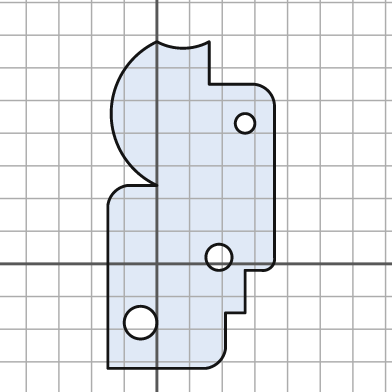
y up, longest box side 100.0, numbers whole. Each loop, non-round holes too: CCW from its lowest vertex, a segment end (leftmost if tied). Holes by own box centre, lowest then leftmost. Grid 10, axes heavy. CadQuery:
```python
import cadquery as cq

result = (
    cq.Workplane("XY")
    .moveTo(-15.0, -32.0)
    .lineTo(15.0, -32.0)
    .threePointArc((19.0, -30.0), (21.0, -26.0))
    .lineTo(21.0, -15.0)
    .lineTo(27.0, -15.0)
    .lineTo(27.0, -2.0)
    .lineTo(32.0, -2.0)
    .threePointArc((35.0, -1.0), (36.0, 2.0))
    .lineTo(36.0, 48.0)
    .threePointArc((34.0, 53.0), (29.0, 55.0))
    .lineTo(16.0, 55.0)
    .lineTo(16.0, 68.0)
    .threePointArc((8.0, 66.0), (0.0, 68.0))
    .threePointArc((-14.0, 46.0), (0.0, 24.0))
    .lineTo(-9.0, 24.0)
    .threePointArc((-13.0, 22.0), (-15.0, 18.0))
    .close()
    .moveTo(-5.0, -18.0)
    .circle(5.0)
    .moveTo(19.0, 2.0)
    .circle(4.0)
    .moveTo(27.0, 43.0)
    .circle(3.0)
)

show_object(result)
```